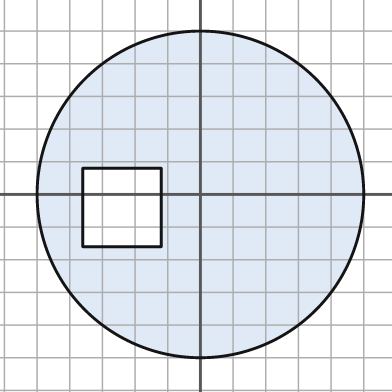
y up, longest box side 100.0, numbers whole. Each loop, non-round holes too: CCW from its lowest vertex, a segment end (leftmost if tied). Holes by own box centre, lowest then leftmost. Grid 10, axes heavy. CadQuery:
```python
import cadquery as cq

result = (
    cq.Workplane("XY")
    .moveTo(0.0, 0.0)
    .circle(50.0)
    .moveTo(-36.0, -16.0)
    .lineTo(-12.0, -16.0)
    .lineTo(-12.0, 8.0)
    .lineTo(-36.0, 8.0)
    .close()
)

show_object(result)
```